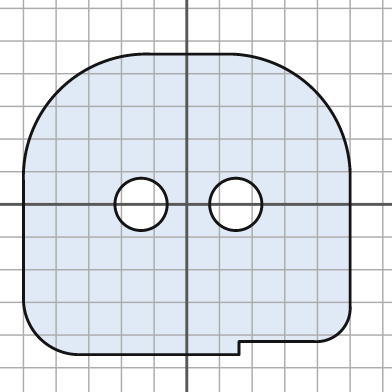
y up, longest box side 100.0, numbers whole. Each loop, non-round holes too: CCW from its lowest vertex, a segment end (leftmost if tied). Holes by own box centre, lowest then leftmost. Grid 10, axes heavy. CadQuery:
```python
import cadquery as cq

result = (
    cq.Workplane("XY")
    .moveTo(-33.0, -46.0)
    .lineTo(16.0, -46.0)
    .lineTo(16.0, -42.0)
    .lineTo(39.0, -42.0)
    .threePointArc((47.0, -39.0), (50.0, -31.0))
    .lineTo(50.0, 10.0)
    .threePointArc((39.0, 35.0), (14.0, 46.0))
    .lineTo(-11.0, 46.0)
    .threePointArc((-39.0, 35.0), (-50.0, 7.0))
    .lineTo(-50.0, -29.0)
    .threePointArc((-45.0, -41.0), (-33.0, -46.0))
    .close()
    .moveTo(-14.0, 0.0)
    .circle(8.0)
    .moveTo(15.0, 0.0)
    .circle(8.0)
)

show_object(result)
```